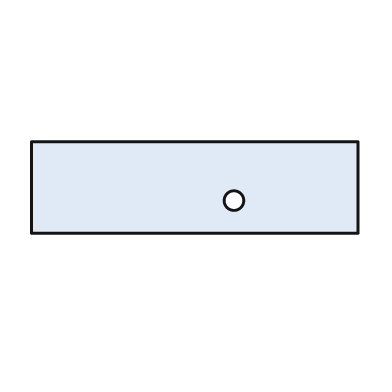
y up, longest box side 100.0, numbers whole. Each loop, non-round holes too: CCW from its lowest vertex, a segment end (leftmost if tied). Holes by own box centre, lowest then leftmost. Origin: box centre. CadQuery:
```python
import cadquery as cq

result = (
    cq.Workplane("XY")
    .moveTo(-50.0, -14.0)
    .lineTo(50.0, -14.0)
    .lineTo(50.0, 14.0)
    .lineTo(-50.0, 14.0)
    .close()
    .moveTo(12.0, -4.0)
    .circle(3.0)
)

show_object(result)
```